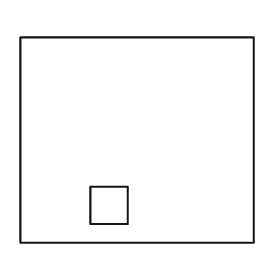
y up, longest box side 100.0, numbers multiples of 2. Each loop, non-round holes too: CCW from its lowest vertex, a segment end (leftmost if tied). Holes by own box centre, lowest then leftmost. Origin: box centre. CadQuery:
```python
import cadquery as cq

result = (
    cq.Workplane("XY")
    .moveTo(-50.0, -44.0)
    .lineTo(50.0, -44.0)
    .lineTo(50.0, 44.0)
    .lineTo(-50.0, 44.0)
    .close()
    .moveTo(-20.0, -36.0)
    .lineTo(-4.0, -36.0)
    .lineTo(-4.0, -20.0)
    .lineTo(-20.0, -20.0)
    .close()
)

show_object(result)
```